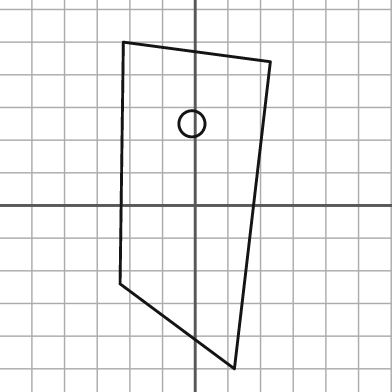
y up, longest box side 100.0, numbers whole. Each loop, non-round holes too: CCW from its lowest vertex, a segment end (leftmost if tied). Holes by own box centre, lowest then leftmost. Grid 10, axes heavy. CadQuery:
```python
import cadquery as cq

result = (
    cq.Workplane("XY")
    .moveTo(12.0, -50.0)
    .lineTo(23.0, 44.0)
    .lineTo(-22.0, 50.0)
    .lineTo(-23.0, -24.0)
    .close()
    .moveTo(-1.0, 25.0)
    .circle(4.0)
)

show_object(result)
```